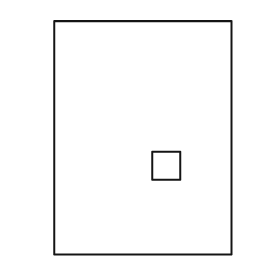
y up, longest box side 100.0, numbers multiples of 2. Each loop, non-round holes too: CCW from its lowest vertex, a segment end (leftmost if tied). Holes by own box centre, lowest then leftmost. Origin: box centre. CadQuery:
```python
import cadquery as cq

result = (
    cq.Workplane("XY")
    .moveTo(-38.0, -50.0)
    .lineTo(38.0, -50.0)
    .lineTo(38.0, 50.0)
    .lineTo(-38.0, 50.0)
    .close()
    .moveTo(4.0, -18.0)
    .lineTo(16.0, -18.0)
    .lineTo(16.0, -6.0)
    .lineTo(4.0, -6.0)
    .close()
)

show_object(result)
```